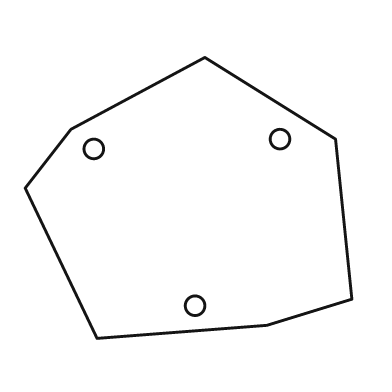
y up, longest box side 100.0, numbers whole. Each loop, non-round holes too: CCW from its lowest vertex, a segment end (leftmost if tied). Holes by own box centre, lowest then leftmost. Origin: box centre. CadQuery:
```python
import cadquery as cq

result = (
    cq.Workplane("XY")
    .moveTo(-28.0, -43.0)
    .lineTo(24.0, -39.0)
    .lineTo(50.0, -31.0)
    .lineTo(45.0, 18.0)
    .lineTo(5.0, 43.0)
    .lineTo(-36.0, 21.0)
    .lineTo(-50.0, 3.0)
    .close()
    .moveTo(2.0, -33.0)
    .circle(3.0)
    .moveTo(-29.0, 15.0)
    .circle(3.0)
    .moveTo(28.0, 18.0)
    .circle(3.0)
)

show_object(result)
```